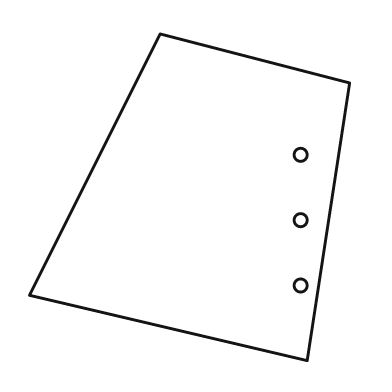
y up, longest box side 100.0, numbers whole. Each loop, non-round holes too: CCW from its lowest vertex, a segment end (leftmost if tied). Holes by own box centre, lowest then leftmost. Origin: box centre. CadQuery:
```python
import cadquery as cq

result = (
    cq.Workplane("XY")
    .moveTo(36.0, -50.0)
    .lineTo(49.0, 35.0)
    .lineTo(-9.0, 50.0)
    .lineTo(-49.0, -30.0)
    .close()
    .moveTo(34.0, -27.0)
    .circle(2.0)
    .moveTo(34.0, -7.0)
    .circle(2.0)
    .moveTo(34.0, 13.0)
    .circle(2.0)
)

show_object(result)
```